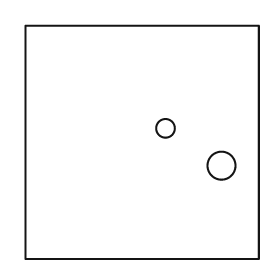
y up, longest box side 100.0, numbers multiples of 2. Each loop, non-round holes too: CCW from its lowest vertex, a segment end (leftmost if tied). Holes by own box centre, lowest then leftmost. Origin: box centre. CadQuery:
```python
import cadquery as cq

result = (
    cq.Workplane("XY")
    .moveTo(-50.0, -50.0)
    .lineTo(50.0, -50.0)
    .lineTo(50.0, 50.0)
    .lineTo(-50.0, 50.0)
    .close()
    .moveTo(34.0, -10.0)
    .circle(6.0)
    .moveTo(10.0, 6.0)
    .circle(4.0)
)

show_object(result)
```